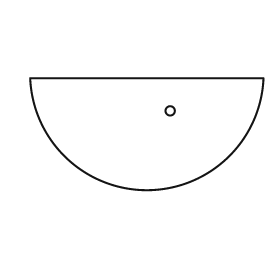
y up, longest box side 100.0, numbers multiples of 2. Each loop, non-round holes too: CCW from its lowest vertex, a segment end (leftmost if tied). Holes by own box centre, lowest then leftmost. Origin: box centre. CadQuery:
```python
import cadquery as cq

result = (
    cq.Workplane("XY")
    .moveTo(-50.0, 24.0)
    .threePointArc((0.0, -24.0), (50.0, 24.0))
    .close()
    .moveTo(10.0, 10.0)
    .circle(2.0)
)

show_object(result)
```